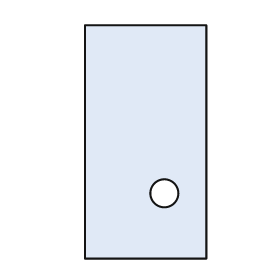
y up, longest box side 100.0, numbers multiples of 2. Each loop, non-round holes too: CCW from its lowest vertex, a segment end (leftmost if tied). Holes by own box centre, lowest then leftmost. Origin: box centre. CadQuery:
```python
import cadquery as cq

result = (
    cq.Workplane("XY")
    .moveTo(-26.0, -50.0)
    .lineTo(26.0, -50.0)
    .lineTo(26.0, 50.0)
    .lineTo(-26.0, 50.0)
    .close()
    .moveTo(8.0, -22.0)
    .circle(6.0)
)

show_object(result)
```